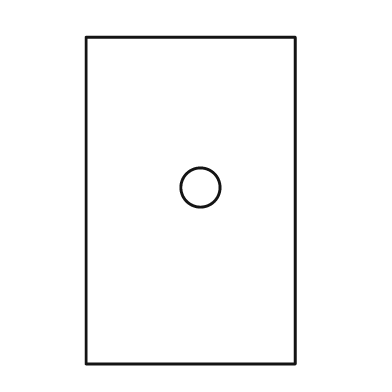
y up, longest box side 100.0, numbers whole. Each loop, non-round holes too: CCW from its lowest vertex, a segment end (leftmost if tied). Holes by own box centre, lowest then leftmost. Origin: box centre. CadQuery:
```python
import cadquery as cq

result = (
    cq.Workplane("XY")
    .moveTo(-32.0, -50.0)
    .lineTo(32.0, -50.0)
    .lineTo(32.0, 50.0)
    .lineTo(-32.0, 50.0)
    .close()
    .moveTo(3.0, 4.0)
    .circle(6.0)
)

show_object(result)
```